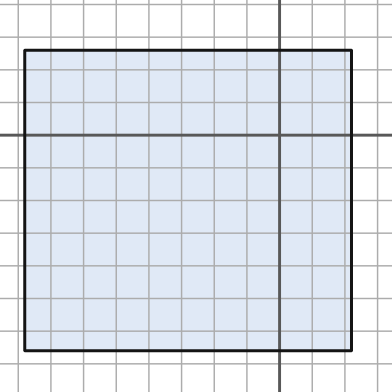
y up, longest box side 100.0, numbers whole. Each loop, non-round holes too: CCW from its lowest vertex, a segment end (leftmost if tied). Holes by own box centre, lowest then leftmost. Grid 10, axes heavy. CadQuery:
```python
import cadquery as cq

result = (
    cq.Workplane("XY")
    .moveTo(-78.0, -66.0)
    .lineTo(22.0, -66.0)
    .lineTo(22.0, 26.0)
    .lineTo(-78.0, 26.0)
    .close()
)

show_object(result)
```